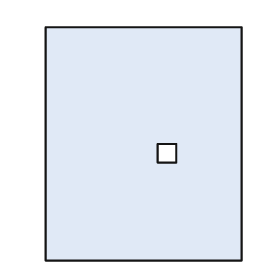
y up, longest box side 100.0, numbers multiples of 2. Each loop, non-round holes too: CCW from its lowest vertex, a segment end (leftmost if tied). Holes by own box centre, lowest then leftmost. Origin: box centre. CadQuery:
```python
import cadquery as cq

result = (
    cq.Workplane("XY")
    .moveTo(-42.0, -50.0)
    .lineTo(42.0, -50.0)
    .lineTo(42.0, 50.0)
    .lineTo(-42.0, 50.0)
    .close()
    .moveTo(6.0, -8.0)
    .lineTo(14.0, -8.0)
    .lineTo(14.0, 0.0)
    .lineTo(6.0, 0.0)
    .close()
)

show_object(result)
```